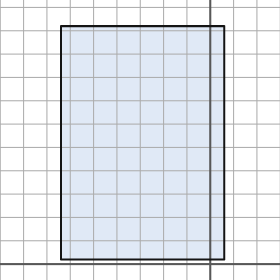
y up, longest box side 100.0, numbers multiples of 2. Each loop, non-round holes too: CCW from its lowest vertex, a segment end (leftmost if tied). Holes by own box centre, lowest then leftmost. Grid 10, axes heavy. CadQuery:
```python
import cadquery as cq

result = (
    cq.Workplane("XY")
    .moveTo(-64.0, 2.0)
    .lineTo(6.0, 2.0)
    .lineTo(6.0, 102.0)
    .lineTo(-64.0, 102.0)
    .close()
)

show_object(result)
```